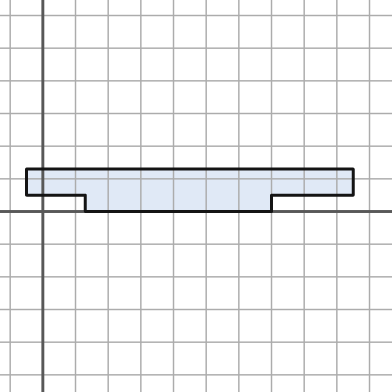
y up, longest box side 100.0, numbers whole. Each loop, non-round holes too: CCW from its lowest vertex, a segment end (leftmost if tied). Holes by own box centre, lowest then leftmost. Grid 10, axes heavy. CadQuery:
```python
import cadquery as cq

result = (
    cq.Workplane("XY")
    .moveTo(13.0, 0.0)
    .lineTo(70.0, 0.0)
    .lineTo(70.0, 5.0)
    .lineTo(95.0, 5.0)
    .lineTo(95.0, 13.0)
    .lineTo(-5.0, 13.0)
    .lineTo(-5.0, 5.0)
    .lineTo(13.0, 5.0)
    .close()
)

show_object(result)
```